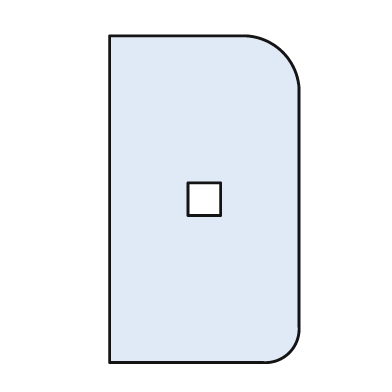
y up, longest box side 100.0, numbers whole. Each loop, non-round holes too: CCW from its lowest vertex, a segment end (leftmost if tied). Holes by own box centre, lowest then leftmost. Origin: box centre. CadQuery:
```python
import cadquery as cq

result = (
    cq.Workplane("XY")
    .moveTo(-29.0, -50.0)
    .lineTo(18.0, -50.0)
    .threePointArc((26.0, -47.0), (29.0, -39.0))
    .lineTo(29.0, 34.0)
    .threePointArc((24.0, 45.0), (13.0, 50.0))
    .lineTo(-29.0, 50.0)
    .close()
    .moveTo(-5.0, -5.0)
    .lineTo(5.0, -5.0)
    .lineTo(5.0, 5.0)
    .lineTo(-5.0, 5.0)
    .close()
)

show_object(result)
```